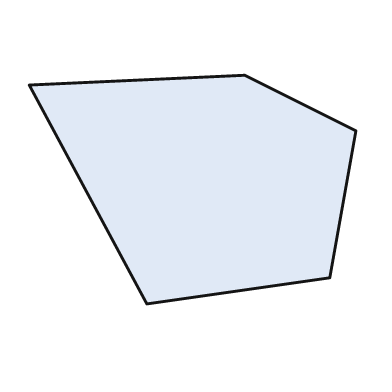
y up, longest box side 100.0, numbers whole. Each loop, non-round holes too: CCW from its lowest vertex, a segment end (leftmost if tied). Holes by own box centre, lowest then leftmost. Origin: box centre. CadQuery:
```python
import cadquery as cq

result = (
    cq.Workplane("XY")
    .moveTo(-14.0, -35.0)
    .lineTo(42.0, -27.0)
    .lineTo(50.0, 18.0)
    .lineTo(16.0, 35.0)
    .lineTo(-50.0, 32.0)
    .close()
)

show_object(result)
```